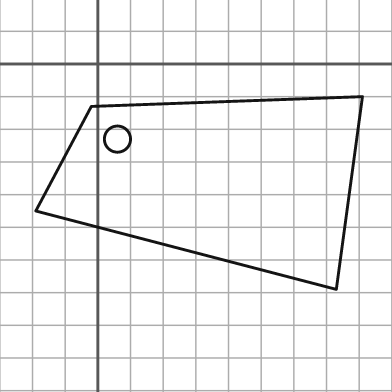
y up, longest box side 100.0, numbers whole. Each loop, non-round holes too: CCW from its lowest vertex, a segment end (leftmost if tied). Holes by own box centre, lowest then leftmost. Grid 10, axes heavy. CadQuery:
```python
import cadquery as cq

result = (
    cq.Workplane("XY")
    .moveTo(73.0, -69.0)
    .lineTo(81.0, -10.0)
    .lineTo(-2.0, -13.0)
    .lineTo(-19.0, -45.0)
    .close()
    .moveTo(6.0, -23.0)
    .circle(4.0)
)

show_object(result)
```